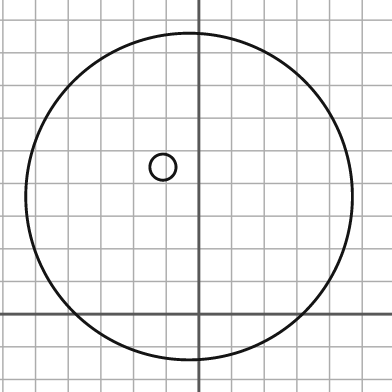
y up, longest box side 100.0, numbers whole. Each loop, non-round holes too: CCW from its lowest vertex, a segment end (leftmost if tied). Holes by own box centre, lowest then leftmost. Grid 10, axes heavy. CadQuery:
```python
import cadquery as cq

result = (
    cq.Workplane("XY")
    .moveTo(-3.0, 36.0)
    .circle(50.0)
    .moveTo(-11.0, 45.0)
    .circle(4.0)
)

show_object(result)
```